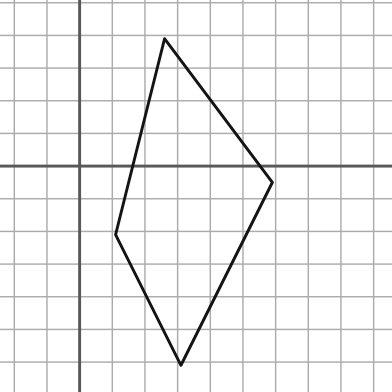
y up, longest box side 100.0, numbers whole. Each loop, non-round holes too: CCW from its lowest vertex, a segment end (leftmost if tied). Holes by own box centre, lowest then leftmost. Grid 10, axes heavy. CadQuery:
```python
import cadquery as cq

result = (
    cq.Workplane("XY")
    .moveTo(31.0, -61.0)
    .lineTo(59.0, -5.0)
    .lineTo(26.0, 39.0)
    .lineTo(11.0, -21.0)
    .close()
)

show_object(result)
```